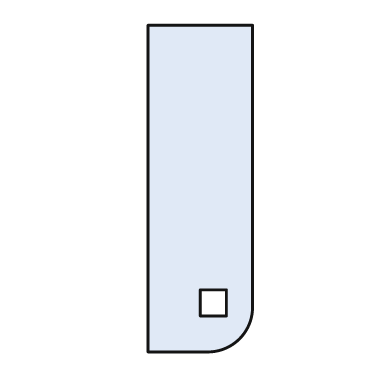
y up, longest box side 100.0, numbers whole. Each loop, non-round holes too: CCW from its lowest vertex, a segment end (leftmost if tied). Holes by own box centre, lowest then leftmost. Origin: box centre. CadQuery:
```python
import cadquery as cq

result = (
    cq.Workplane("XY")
    .moveTo(-16.0, -50.0)
    .lineTo(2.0, -50.0)
    .threePointArc((12.0, -46.0), (16.0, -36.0))
    .lineTo(16.0, 50.0)
    .lineTo(-16.0, 50.0)
    .close()
    .moveTo(0.0, -39.0)
    .lineTo(8.0, -39.0)
    .lineTo(8.0, -31.0)
    .lineTo(0.0, -31.0)
    .close()
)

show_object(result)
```